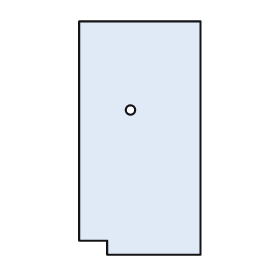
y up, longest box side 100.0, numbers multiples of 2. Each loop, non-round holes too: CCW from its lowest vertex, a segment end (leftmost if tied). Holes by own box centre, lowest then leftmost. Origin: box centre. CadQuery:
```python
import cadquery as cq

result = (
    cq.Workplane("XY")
    .moveTo(-14.0, -50.0)
    .lineTo(26.0, -50.0)
    .lineTo(26.0, 50.0)
    .lineTo(-26.0, 50.0)
    .lineTo(-26.0, -44.0)
    .lineTo(-14.0, -44.0)
    .close()
    .moveTo(-4.0, 12.0)
    .circle(2.0)
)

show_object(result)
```